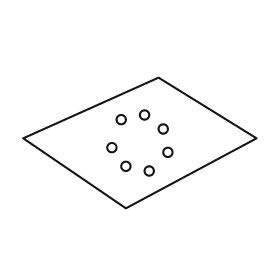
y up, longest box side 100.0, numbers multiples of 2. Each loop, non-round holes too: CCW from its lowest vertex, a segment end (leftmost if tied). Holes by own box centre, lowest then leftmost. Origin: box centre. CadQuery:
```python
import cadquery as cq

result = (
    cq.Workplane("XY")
    .moveTo(-6.0, -28.0)
    .lineTo(50.0, 2.0)
    .lineTo(8.0, 28.0)
    .lineTo(-50.0, 2.0)
    .close()
    .moveTo(4.0, -12.0)
    .circle(2.0)
    .moveTo(-6.0, -10.0)
    .circle(2.0)
    .moveTo(12.0, -4.0)
    .circle(2.0)
    .moveTo(-12.0, -2.0)
    .circle(2.0)
    .moveTo(10.0, 6.0)
    .circle(2.0)
    .moveTo(-8.0, 10.0)
    .circle(2.0)
    .moveTo(2.0, 12.0)
    .circle(2.0)
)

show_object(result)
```